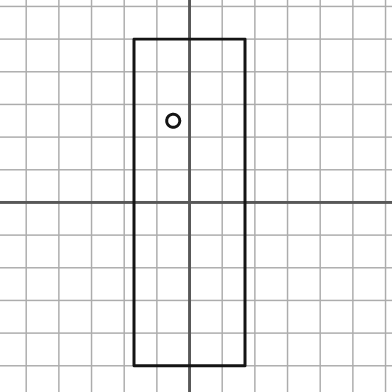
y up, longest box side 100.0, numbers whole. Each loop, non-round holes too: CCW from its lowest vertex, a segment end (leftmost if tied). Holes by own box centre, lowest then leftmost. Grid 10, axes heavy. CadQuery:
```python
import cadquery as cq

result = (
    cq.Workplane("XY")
    .moveTo(-17.0, -50.0)
    .lineTo(17.0, -50.0)
    .lineTo(17.0, 50.0)
    .lineTo(-17.0, 50.0)
    .close()
    .moveTo(-5.0, 25.0)
    .circle(2.0)
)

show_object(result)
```